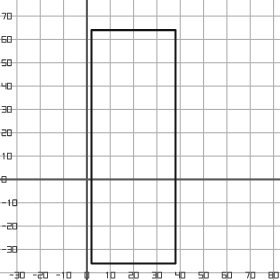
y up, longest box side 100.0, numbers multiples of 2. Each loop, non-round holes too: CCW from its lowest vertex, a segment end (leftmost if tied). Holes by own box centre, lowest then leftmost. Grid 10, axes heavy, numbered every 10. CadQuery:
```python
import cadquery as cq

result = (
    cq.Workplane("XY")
    .moveTo(2.0, -36.0)
    .lineTo(38.0, -36.0)
    .lineTo(38.0, 64.0)
    .lineTo(2.0, 64.0)
    .close()
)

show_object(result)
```